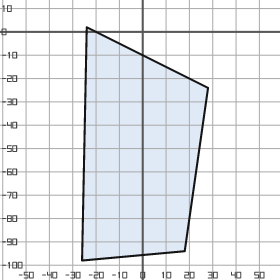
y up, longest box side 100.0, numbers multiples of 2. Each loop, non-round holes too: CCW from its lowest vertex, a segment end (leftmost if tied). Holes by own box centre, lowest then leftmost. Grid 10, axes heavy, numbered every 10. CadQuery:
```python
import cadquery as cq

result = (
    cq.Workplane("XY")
    .moveTo(-26.0, -98.0)
    .lineTo(18.0, -94.0)
    .lineTo(28.0, -24.0)
    .lineTo(-24.0, 2.0)
    .close()
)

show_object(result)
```